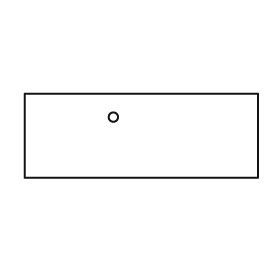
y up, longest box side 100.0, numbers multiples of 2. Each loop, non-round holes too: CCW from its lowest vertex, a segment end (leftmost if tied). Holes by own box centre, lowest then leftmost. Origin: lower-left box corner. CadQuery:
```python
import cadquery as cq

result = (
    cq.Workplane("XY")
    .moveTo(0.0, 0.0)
    .lineTo(100.0, 0.0)
    .lineTo(100.0, 36.0)
    .lineTo(0.0, 36.0)
    .close()
    .moveTo(38.0, 26.0)
    .circle(2.0)
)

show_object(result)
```